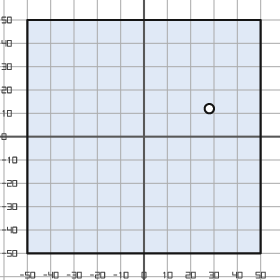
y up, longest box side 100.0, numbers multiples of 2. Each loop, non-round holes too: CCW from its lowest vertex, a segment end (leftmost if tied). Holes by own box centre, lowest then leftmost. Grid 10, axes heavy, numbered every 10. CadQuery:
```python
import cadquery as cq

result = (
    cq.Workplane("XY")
    .moveTo(-50.0, -50.0)
    .lineTo(50.0, -50.0)
    .lineTo(50.0, 50.0)
    .lineTo(-50.0, 50.0)
    .close()
    .moveTo(28.0, 12.0)
    .circle(2.0)
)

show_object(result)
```